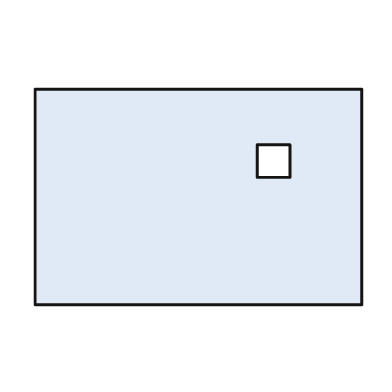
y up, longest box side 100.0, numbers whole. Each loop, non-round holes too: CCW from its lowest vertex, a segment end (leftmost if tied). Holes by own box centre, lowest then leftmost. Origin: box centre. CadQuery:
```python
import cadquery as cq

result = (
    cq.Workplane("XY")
    .moveTo(-50.0, -33.0)
    .lineTo(50.0, -33.0)
    .lineTo(50.0, 33.0)
    .lineTo(-50.0, 33.0)
    .close()
    .moveTo(18.0, 6.0)
    .lineTo(28.0, 6.0)
    .lineTo(28.0, 16.0)
    .lineTo(18.0, 16.0)
    .close()
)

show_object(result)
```